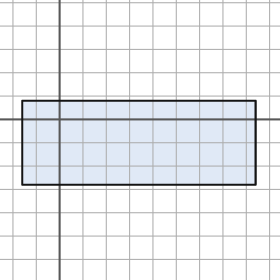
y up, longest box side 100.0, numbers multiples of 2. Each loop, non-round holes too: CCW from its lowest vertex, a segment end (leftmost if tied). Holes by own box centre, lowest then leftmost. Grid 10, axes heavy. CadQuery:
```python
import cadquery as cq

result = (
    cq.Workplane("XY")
    .moveTo(-16.0, -28.0)
    .lineTo(84.0, -28.0)
    .lineTo(84.0, 8.0)
    .lineTo(-16.0, 8.0)
    .close()
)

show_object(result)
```